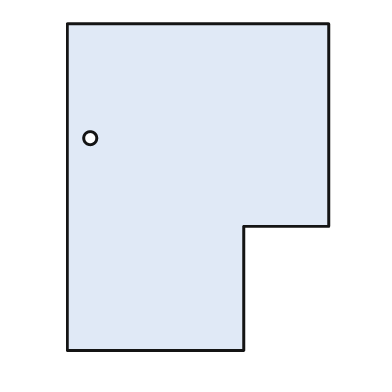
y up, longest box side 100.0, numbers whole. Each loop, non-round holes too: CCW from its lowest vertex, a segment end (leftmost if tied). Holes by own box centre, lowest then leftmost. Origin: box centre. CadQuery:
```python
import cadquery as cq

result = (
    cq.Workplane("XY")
    .moveTo(-40.0, -50.0)
    .lineTo(14.0, -50.0)
    .lineTo(14.0, -12.0)
    .lineTo(40.0, -12.0)
    .lineTo(40.0, 50.0)
    .lineTo(-40.0, 50.0)
    .close()
    .moveTo(-33.0, 15.0)
    .circle(2.0)
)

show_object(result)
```